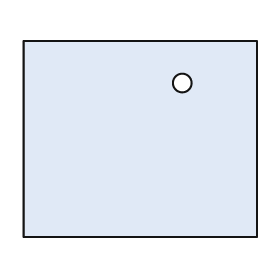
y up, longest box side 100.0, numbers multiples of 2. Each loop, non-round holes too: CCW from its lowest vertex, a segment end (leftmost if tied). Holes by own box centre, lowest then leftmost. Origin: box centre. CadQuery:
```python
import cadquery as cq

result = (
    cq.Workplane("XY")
    .moveTo(-50.0, -42.0)
    .lineTo(50.0, -42.0)
    .lineTo(50.0, 42.0)
    .lineTo(-50.0, 42.0)
    .close()
    .moveTo(18.0, 24.0)
    .circle(4.0)
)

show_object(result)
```